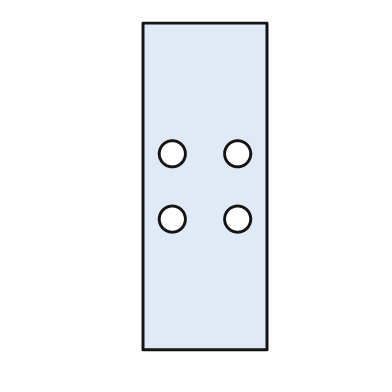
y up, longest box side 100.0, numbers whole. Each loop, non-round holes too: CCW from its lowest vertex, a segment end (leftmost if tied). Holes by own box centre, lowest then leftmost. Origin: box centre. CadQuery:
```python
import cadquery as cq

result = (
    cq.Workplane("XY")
    .moveTo(-19.0, -50.0)
    .lineTo(19.0, -50.0)
    .lineTo(19.0, 50.0)
    .lineTo(-19.0, 50.0)
    .close()
    .moveTo(-10.0, -10.0)
    .circle(4.0)
    .moveTo(10.0, -10.0)
    .circle(4.0)
    .moveTo(-10.0, 10.0)
    .circle(4.0)
    .moveTo(10.0, 10.0)
    .circle(4.0)
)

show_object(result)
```